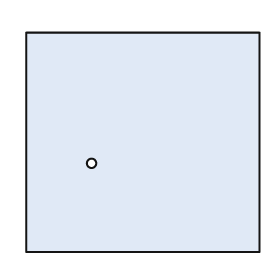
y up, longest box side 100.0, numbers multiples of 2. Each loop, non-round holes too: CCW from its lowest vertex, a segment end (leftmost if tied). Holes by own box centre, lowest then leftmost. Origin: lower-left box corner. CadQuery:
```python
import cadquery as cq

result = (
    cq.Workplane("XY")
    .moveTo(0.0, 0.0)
    .lineTo(100.0, 0.0)
    .lineTo(100.0, 94.0)
    .lineTo(0.0, 94.0)
    .close()
    .moveTo(28.0, 38.0)
    .circle(2.0)
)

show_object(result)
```